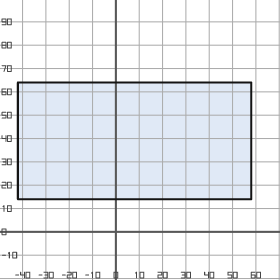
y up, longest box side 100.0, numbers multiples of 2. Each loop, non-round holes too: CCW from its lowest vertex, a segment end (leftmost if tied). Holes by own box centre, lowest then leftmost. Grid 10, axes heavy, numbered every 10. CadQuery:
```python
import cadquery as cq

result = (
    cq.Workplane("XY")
    .moveTo(-42.0, 14.0)
    .lineTo(58.0, 14.0)
    .lineTo(58.0, 64.0)
    .lineTo(-42.0, 64.0)
    .close()
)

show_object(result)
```